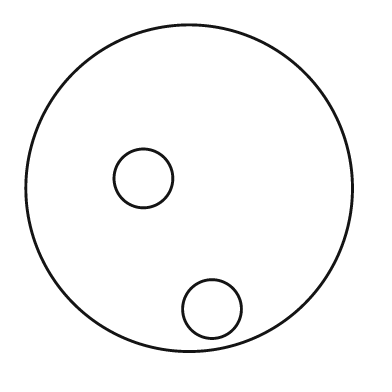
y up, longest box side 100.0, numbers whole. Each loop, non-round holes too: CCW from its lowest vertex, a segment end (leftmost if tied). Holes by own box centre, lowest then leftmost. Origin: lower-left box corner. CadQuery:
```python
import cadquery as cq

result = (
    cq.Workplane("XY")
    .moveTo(50.0, 50.0)
    .circle(50.0)
    .moveTo(57.0, 13.0)
    .circle(9.0)
    .moveTo(36.0, 53.0)
    .circle(9.0)
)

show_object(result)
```